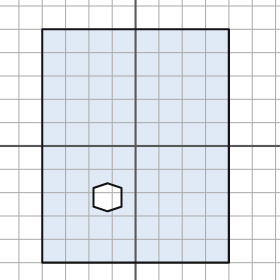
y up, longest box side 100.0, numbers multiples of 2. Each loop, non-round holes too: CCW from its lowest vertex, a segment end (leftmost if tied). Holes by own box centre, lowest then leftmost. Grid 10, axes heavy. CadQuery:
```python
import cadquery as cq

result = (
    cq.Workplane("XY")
    .moveTo(-40.0, -50.0)
    .lineTo(40.0, -50.0)
    .lineTo(40.0, 50.0)
    .lineTo(-40.0, 50.0)
    .close()
    .moveTo(-12.0, -28.0)
    .lineTo(-6.0, -26.0)
    .lineTo(-6.0, -18.0)
    .lineTo(-12.0, -16.0)
    .lineTo(-18.0, -18.0)
    .lineTo(-18.0, -26.0)
    .close()
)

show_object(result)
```